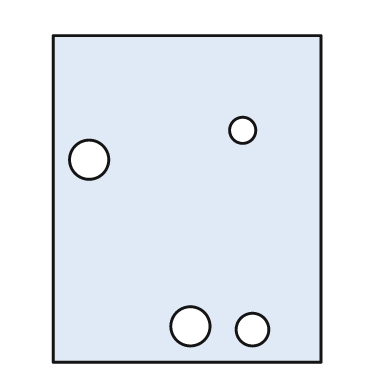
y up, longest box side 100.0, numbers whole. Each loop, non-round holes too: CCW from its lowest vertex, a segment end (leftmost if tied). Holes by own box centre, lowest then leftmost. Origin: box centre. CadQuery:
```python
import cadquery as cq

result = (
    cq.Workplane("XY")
    .moveTo(-41.0, -50.0)
    .lineTo(41.0, -50.0)
    .lineTo(41.0, 50.0)
    .lineTo(-41.0, 50.0)
    .close()
    .moveTo(20.0, -40.0)
    .circle(5.0)
    .moveTo(1.0, -39.0)
    .circle(6.0)
    .moveTo(-30.0, 12.0)
    .circle(6.0)
    .moveTo(17.0, 21.0)
    .circle(4.0)
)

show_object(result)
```